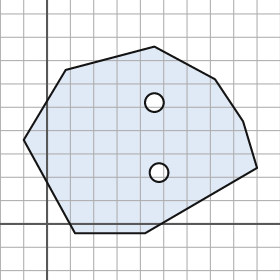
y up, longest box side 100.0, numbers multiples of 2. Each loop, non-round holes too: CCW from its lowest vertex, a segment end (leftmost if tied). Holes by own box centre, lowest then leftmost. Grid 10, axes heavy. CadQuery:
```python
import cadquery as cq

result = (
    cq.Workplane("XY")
    .moveTo(12.0, -4.0)
    .lineTo(42.0, -4.0)
    .lineTo(90.0, 24.0)
    .lineTo(84.0, 44.0)
    .lineTo(72.0, 62.0)
    .lineTo(46.0, 76.0)
    .lineTo(8.0, 66.0)
    .lineTo(-10.0, 36.0)
    .close()
    .moveTo(48.0, 22.0)
    .circle(4.0)
    .moveTo(46.0, 52.0)
    .circle(4.0)
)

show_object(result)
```